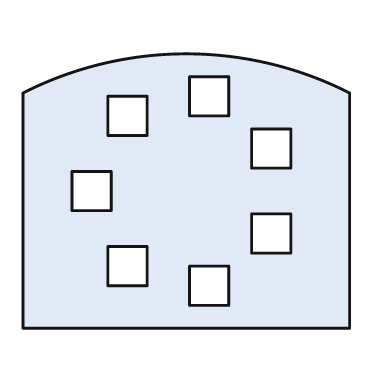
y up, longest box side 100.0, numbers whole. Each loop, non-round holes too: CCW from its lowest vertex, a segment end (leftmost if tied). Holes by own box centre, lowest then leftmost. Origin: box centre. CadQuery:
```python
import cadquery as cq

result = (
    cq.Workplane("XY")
    .moveTo(-50.0, -42.0)
    .lineTo(50.0, -42.0)
    .lineTo(50.0, 30.0)
    .threePointArc((0.0, 42.0), (-50.0, 30.0))
    .close()
    .moveTo(1.0, -35.0)
    .lineTo(13.0, -35.0)
    .lineTo(13.0, -23.0)
    .lineTo(1.0, -23.0)
    .close()
    .moveTo(-24.0, -29.0)
    .lineTo(-12.0, -29.0)
    .lineTo(-12.0, -17.0)
    .lineTo(-24.0, -17.0)
    .close()
    .moveTo(20.0, -19.0)
    .lineTo(32.0, -19.0)
    .lineTo(32.0, -7.0)
    .lineTo(20.0, -7.0)
    .close()
    .moveTo(-35.0, -6.0)
    .lineTo(-23.0, -6.0)
    .lineTo(-23.0, 6.0)
    .lineTo(-35.0, 6.0)
    .close()
    .moveTo(20.0, 7.0)
    .lineTo(32.0, 7.0)
    .lineTo(32.0, 19.0)
    .lineTo(20.0, 19.0)
    .close()
    .moveTo(-24.0, 17.0)
    .lineTo(-12.0, 17.0)
    .lineTo(-12.0, 29.0)
    .lineTo(-24.0, 29.0)
    .close()
    .moveTo(1.0, 23.0)
    .lineTo(13.0, 23.0)
    .lineTo(13.0, 35.0)
    .lineTo(1.0, 35.0)
    .close()
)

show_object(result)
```